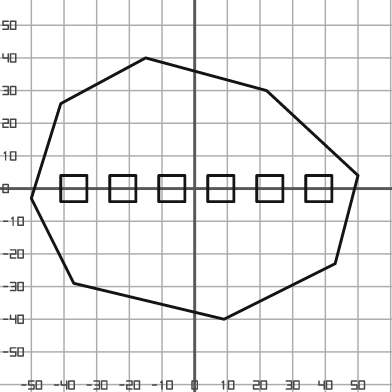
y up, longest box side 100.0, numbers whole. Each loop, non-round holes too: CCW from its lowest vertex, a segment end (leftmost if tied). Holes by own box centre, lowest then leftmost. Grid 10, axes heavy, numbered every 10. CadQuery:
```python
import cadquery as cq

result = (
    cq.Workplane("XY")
    .moveTo(9.0, -40.0)
    .lineTo(43.0, -23.0)
    .lineTo(50.0, 4.0)
    .lineTo(22.0, 30.0)
    .lineTo(-15.0, 40.0)
    .lineTo(-41.0, 26.0)
    .lineTo(-50.0, -3.0)
    .lineTo(-37.0, -29.0)
    .close()
    .moveTo(-41.0, -4.0)
    .lineTo(-33.0, -4.0)
    .lineTo(-33.0, 4.0)
    .lineTo(-41.0, 4.0)
    .close()
    .moveTo(-26.0, -4.0)
    .lineTo(-18.0, -4.0)
    .lineTo(-18.0, 4.0)
    .lineTo(-26.0, 4.0)
    .close()
    .moveTo(-11.0, -4.0)
    .lineTo(-3.0, -4.0)
    .lineTo(-3.0, 4.0)
    .lineTo(-11.0, 4.0)
    .close()
    .moveTo(4.0, -4.0)
    .lineTo(12.0, -4.0)
    .lineTo(12.0, 4.0)
    .lineTo(4.0, 4.0)
    .close()
    .moveTo(19.0, -4.0)
    .lineTo(27.0, -4.0)
    .lineTo(27.0, 4.0)
    .lineTo(19.0, 4.0)
    .close()
    .moveTo(34.0, -4.0)
    .lineTo(42.0, -4.0)
    .lineTo(42.0, 4.0)
    .lineTo(34.0, 4.0)
    .close()
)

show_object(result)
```